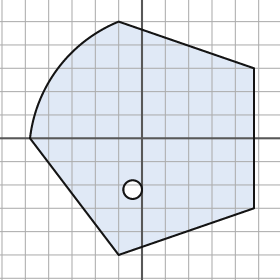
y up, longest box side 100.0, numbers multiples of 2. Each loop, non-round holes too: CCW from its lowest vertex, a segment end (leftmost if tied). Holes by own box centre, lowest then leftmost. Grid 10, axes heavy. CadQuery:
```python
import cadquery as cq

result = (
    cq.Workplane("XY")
    .moveTo(-10.0, -50.0)
    .lineTo(48.0, -30.0)
    .lineTo(48.0, 30.0)
    .lineTo(-10.0, 50.0)
    .threePointArc((-36.0, 30.0), (-48.0, 0.0))
    .close()
    .moveTo(-4.0, -22.0)
    .circle(4.0)
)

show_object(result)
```